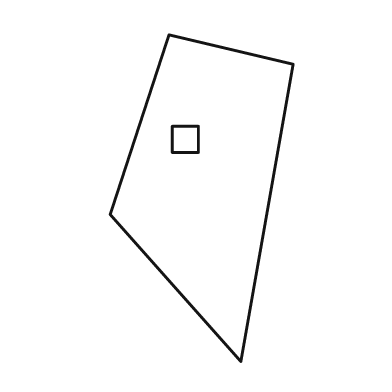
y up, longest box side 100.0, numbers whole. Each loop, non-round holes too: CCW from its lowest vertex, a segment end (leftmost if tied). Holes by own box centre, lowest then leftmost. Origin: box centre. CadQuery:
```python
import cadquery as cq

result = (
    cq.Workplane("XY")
    .moveTo(12.0, -50.0)
    .lineTo(28.0, 41.0)
    .lineTo(-10.0, 50.0)
    .lineTo(-28.0, -5.0)
    .close()
    .moveTo(-9.0, 14.0)
    .lineTo(-1.0, 14.0)
    .lineTo(-1.0, 22.0)
    .lineTo(-9.0, 22.0)
    .close()
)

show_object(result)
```